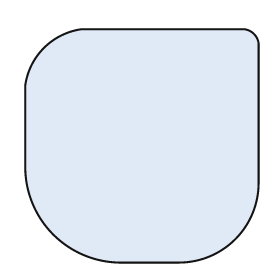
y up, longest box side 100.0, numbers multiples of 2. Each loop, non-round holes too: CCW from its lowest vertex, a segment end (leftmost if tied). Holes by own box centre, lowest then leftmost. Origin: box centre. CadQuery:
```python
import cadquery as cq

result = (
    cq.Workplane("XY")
    .moveTo(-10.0, -50.0)
    .lineTo(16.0, -50.0)
    .threePointArc((40.0, -40.0), (50.0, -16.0))
    .lineTo(50.0, 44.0)
    .threePointArc((48.0, 48.0), (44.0, 50.0))
    .lineTo(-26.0, 50.0)
    .threePointArc((-42.0, 42.0), (-50.0, 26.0))
    .lineTo(-50.0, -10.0)
    .threePointArc((-38.0, -38.0), (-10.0, -50.0))
    .close()
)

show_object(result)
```